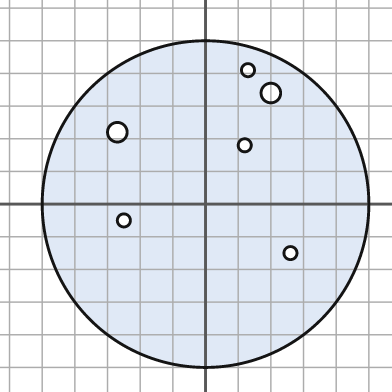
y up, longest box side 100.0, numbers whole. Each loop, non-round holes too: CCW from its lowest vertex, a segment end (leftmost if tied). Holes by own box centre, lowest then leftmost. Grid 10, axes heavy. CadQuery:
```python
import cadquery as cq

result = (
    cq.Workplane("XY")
    .moveTo(0.0, 0.0)
    .circle(50.0)
    .moveTo(26.0, -15.0)
    .circle(2.0)
    .moveTo(-25.0, -5.0)
    .circle(2.0)
    .moveTo(12.0, 18.0)
    .circle(2.0)
    .moveTo(-27.0, 22.0)
    .circle(3.0)
    .moveTo(20.0, 34.0)
    .circle(3.0)
    .moveTo(13.0, 41.0)
    .circle(2.0)
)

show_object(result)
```